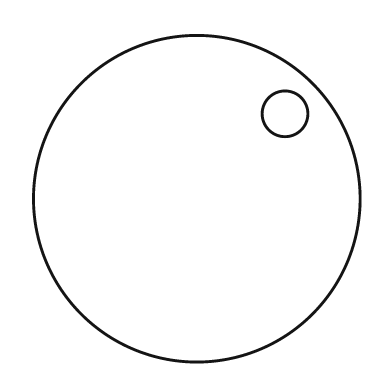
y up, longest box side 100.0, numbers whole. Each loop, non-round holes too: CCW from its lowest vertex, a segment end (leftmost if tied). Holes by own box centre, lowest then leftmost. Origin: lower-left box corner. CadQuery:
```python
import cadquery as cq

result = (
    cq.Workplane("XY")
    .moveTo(50.0, 50.0)
    .circle(50.0)
    .moveTo(77.0, 76.0)
    .circle(7.0)
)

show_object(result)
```